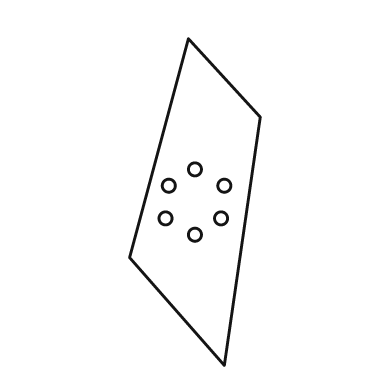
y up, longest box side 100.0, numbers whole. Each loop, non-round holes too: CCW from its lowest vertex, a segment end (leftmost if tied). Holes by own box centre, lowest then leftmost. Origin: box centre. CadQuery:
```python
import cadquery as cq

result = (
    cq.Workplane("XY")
    .moveTo(9.0, -50.0)
    .lineTo(20.0, 26.0)
    .lineTo(-2.0, 50.0)
    .lineTo(-20.0, -17.0)
    .close()
    .moveTo(0.0, -10.0)
    .circle(2.0)
    .moveTo(-9.0, -5.0)
    .circle(2.0)
    .moveTo(8.0, -5.0)
    .circle(2.0)
    .moveTo(-8.0, 5.0)
    .circle(2.0)
    .moveTo(9.0, 5.0)
    .circle(2.0)
    .moveTo(0.0, 10.0)
    .circle(2.0)
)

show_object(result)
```